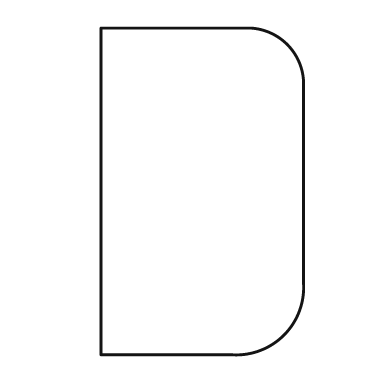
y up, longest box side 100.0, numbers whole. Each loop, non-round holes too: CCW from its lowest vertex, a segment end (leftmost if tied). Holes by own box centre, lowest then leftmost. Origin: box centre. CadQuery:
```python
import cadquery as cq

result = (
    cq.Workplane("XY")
    .moveTo(-31.0, -50.0)
    .lineTo(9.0, -50.0)
    .threePointArc((25.0, -44.0), (31.0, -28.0))
    .lineTo(31.0, 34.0)
    .threePointArc((26.0, 45.0), (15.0, 50.0))
    .lineTo(-31.0, 50.0)
    .close()
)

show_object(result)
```